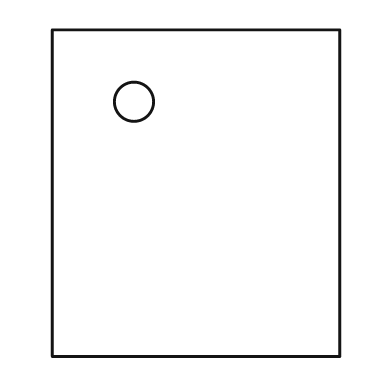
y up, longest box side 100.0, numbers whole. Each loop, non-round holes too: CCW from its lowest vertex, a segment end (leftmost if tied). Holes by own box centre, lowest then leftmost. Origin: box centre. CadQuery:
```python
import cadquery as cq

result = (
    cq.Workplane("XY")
    .moveTo(-44.0, -50.0)
    .lineTo(44.0, -50.0)
    .lineTo(44.0, 50.0)
    .lineTo(-44.0, 50.0)
    .close()
    .moveTo(-19.0, 28.0)
    .circle(6.0)
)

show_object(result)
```